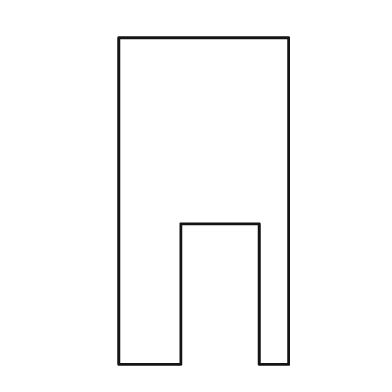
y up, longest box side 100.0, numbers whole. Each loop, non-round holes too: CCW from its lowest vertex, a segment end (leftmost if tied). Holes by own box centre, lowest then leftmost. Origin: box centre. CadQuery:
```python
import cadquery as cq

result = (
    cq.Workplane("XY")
    .moveTo(-26.0, -50.0)
    .lineTo(-7.0, -50.0)
    .lineTo(-7.0, -7.0)
    .lineTo(17.0, -7.0)
    .lineTo(17.0, -50.0)
    .lineTo(26.0, -50.0)
    .lineTo(26.0, 50.0)
    .lineTo(-26.0, 50.0)
    .close()
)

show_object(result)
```